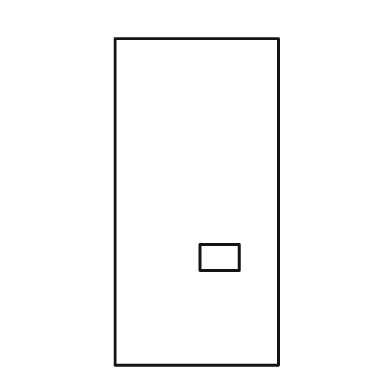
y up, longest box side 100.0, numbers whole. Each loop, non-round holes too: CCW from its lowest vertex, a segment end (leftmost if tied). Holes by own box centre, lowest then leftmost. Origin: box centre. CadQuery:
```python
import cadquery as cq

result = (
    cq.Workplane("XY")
    .moveTo(-25.0, -50.0)
    .lineTo(25.0, -50.0)
    .lineTo(25.0, 50.0)
    .lineTo(-25.0, 50.0)
    .close()
    .moveTo(1.0, -21.0)
    .lineTo(13.0, -21.0)
    .lineTo(13.0, -13.0)
    .lineTo(1.0, -13.0)
    .close()
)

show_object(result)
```